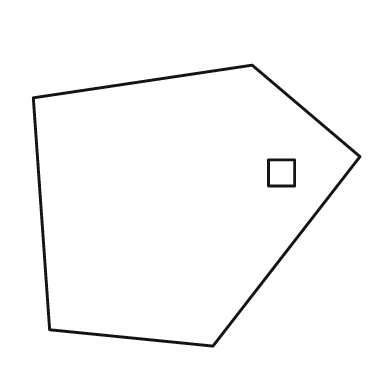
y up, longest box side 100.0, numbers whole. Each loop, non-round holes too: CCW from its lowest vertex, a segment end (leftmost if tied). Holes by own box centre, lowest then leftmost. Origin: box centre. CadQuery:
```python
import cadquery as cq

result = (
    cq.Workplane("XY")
    .moveTo(5.0, -43.0)
    .lineTo(50.0, 15.0)
    .lineTo(17.0, 43.0)
    .lineTo(-50.0, 33.0)
    .lineTo(-45.0, -38.0)
    .close()
    .moveTo(22.0, 6.0)
    .lineTo(30.0, 6.0)
    .lineTo(30.0, 14.0)
    .lineTo(22.0, 14.0)
    .close()
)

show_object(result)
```